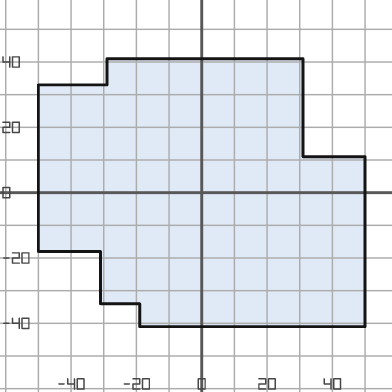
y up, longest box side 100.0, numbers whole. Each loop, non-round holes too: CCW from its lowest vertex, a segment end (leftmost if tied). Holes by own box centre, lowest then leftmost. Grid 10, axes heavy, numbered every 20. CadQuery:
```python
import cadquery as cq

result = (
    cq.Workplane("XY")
    .moveTo(-19.0, -41.0)
    .lineTo(50.0, -41.0)
    .lineTo(50.0, 11.0)
    .lineTo(31.0, 11.0)
    .lineTo(31.0, 41.0)
    .lineTo(-29.0, 41.0)
    .lineTo(-29.0, 33.0)
    .lineTo(-50.0, 33.0)
    .lineTo(-50.0, -18.0)
    .lineTo(-31.0, -18.0)
    .lineTo(-31.0, -34.0)
    .lineTo(-19.0, -34.0)
    .close()
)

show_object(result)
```